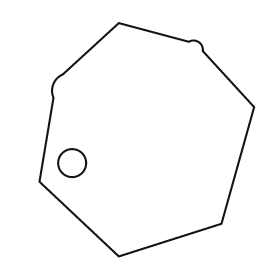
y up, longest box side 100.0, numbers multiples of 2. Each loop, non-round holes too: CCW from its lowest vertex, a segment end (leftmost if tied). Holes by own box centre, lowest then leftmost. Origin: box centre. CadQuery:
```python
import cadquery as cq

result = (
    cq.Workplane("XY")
    .moveTo(-12.0, -50.0)
    .lineTo(32.0, -36.0)
    .lineTo(46.0, 14.0)
    .lineTo(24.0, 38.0)
    .threePointArc((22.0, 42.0), (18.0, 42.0))
    .lineTo(-12.0, 50.0)
    .lineTo(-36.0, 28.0)
    .threePointArc((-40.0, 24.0), (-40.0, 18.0))
    .lineTo(-46.0, -18.0)
    .close()
    .moveTo(-32.0, -10.0)
    .circle(6.0)
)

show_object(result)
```